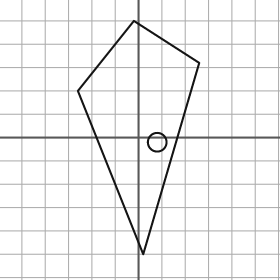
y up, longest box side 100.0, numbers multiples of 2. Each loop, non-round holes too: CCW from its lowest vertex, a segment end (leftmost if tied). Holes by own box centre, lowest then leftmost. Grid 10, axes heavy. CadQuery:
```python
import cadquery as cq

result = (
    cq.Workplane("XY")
    .moveTo(2.0, -50.0)
    .lineTo(26.0, 32.0)
    .lineTo(-2.0, 50.0)
    .lineTo(-26.0, 20.0)
    .close()
    .moveTo(8.0, -2.0)
    .circle(4.0)
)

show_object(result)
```